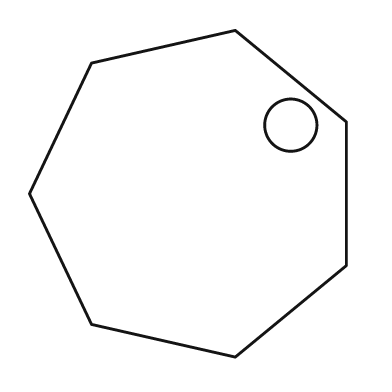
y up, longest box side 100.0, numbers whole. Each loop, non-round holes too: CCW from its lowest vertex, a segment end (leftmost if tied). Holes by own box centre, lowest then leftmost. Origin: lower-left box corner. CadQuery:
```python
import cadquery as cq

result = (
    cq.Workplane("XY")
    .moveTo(63.0, 0.0)
    .lineTo(97.0, 28.0)
    .lineTo(97.0, 72.0)
    .lineTo(63.0, 100.0)
    .lineTo(19.0, 90.0)
    .lineTo(0.0, 50.0)
    .lineTo(19.0, 10.0)
    .close()
    .moveTo(80.0, 71.0)
    .circle(8.0)
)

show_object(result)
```